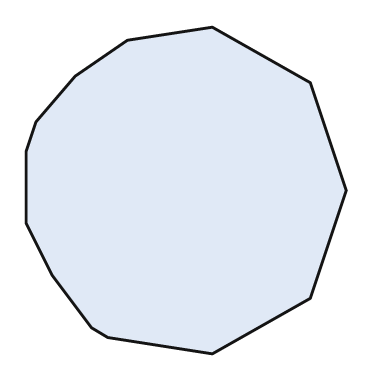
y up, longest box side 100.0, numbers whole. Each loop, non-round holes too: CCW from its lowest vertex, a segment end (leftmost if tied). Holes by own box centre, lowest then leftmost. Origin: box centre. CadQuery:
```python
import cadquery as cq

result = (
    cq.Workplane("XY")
    .moveTo(8.0, -50.0)
    .lineTo(38.0, -33.0)
    .lineTo(49.0, 0.0)
    .lineTo(38.0, 33.0)
    .lineTo(8.0, 50.0)
    .lineTo(-18.0, 46.0)
    .lineTo(-34.0, 35.0)
    .lineTo(-46.0, 21.0)
    .lineTo(-49.0, 12.0)
    .lineTo(-49.0, -10.0)
    .lineTo(-41.0, -26.0)
    .lineTo(-29.0, -42.0)
    .lineTo(-24.0, -45.0)
    .close()
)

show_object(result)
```